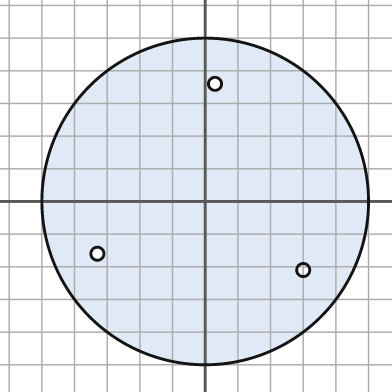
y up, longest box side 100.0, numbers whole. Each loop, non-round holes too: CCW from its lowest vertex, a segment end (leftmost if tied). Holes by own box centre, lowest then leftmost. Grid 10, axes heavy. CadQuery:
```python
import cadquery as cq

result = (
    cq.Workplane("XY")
    .moveTo(0.0, 0.0)
    .circle(50.0)
    .moveTo(30.0, -21.0)
    .circle(2.0)
    .moveTo(-33.0, -16.0)
    .circle(2.0)
    .moveTo(3.0, 36.0)
    .circle(2.0)
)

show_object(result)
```